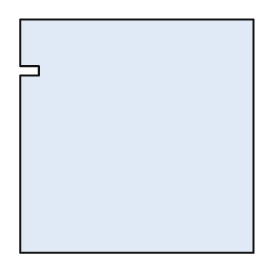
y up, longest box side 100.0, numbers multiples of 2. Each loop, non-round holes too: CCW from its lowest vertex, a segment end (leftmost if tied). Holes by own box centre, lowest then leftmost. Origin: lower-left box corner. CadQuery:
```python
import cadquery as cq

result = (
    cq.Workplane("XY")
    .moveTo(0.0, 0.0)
    .lineTo(100.0, 0.0)
    .lineTo(100.0, 100.0)
    .lineTo(0.0, 100.0)
    .lineTo(0.0, 80.0)
    .lineTo(8.0, 80.0)
    .lineTo(8.0, 76.0)
    .lineTo(0.0, 76.0)
    .close()
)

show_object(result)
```